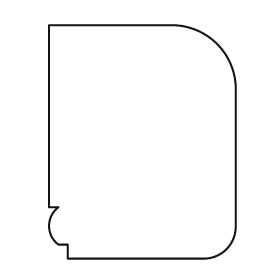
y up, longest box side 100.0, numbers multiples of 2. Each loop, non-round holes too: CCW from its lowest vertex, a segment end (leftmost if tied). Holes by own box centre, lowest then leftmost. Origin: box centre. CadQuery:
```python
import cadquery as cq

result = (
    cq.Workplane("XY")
    .moveTo(-32.0, -50.0)
    .lineTo(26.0, -50.0)
    .threePointArc((36.0, -46.0), (40.0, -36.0))
    .lineTo(40.0, 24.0)
    .threePointArc((32.0, 42.0), (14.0, 50.0))
    .lineTo(-40.0, 50.0)
    .lineTo(-40.0, -28.0)
    .lineTo(-36.0, -28.0)
    .threePointArc((-40.0, -36.0), (-36.0, -44.0))
    .lineTo(-32.0, -44.0)
    .close()
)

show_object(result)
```